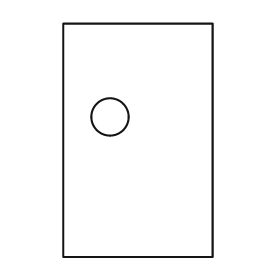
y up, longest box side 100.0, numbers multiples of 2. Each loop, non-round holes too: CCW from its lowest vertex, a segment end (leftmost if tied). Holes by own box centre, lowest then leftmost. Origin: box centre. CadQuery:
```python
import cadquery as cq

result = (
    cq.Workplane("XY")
    .moveTo(-32.0, -50.0)
    .lineTo(32.0, -50.0)
    .lineTo(32.0, 50.0)
    .lineTo(-32.0, 50.0)
    .close()
    .moveTo(-12.0, 10.0)
    .circle(8.0)
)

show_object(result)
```